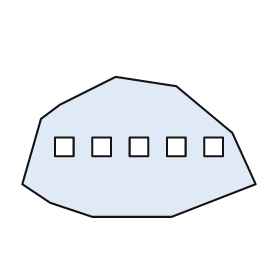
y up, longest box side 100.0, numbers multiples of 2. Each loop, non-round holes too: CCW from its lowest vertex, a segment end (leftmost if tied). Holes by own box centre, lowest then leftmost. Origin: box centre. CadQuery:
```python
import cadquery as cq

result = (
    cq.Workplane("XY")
    .moveTo(-20.0, -30.0)
    .lineTo(14.0, -30.0)
    .lineTo(50.0, -16.0)
    .lineTo(40.0, 6.0)
    .lineTo(16.0, 26.0)
    .lineTo(-10.0, 30.0)
    .lineTo(-34.0, 18.0)
    .lineTo(-42.0, 12.0)
    .lineTo(-50.0, -16.0)
    .lineTo(-38.0, -24.0)
    .close()
    .moveTo(-36.0, -4.0)
    .lineTo(-28.0, -4.0)
    .lineTo(-28.0, 4.0)
    .lineTo(-36.0, 4.0)
    .close()
    .moveTo(-20.0, -4.0)
    .lineTo(-12.0, -4.0)
    .lineTo(-12.0, 4.0)
    .lineTo(-20.0, 4.0)
    .close()
    .moveTo(-4.0, -4.0)
    .lineTo(4.0, -4.0)
    .lineTo(4.0, 4.0)
    .lineTo(-4.0, 4.0)
    .close()
    .moveTo(12.0, -4.0)
    .lineTo(20.0, -4.0)
    .lineTo(20.0, 4.0)
    .lineTo(12.0, 4.0)
    .close()
    .moveTo(28.0, -4.0)
    .lineTo(36.0, -4.0)
    .lineTo(36.0, 4.0)
    .lineTo(28.0, 4.0)
    .close()
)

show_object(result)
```